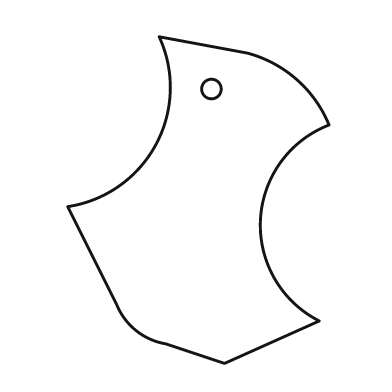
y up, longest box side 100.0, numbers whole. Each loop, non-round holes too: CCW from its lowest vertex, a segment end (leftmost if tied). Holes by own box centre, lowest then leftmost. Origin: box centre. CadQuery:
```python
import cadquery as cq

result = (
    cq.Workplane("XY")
    .moveTo(8.0, -50.0)
    .lineTo(37.0, -37.0)
    .threePointArc((19.0, -6.0), (40.0, 23.0))
    .threePointArc((30.0, 37.0), (15.0, 45.0))
    .lineTo(-12.0, 50.0)
    .threePointArc((-13.0, 17.0), (-40.0, -2.0))
    .lineTo(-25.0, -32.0)
    .threePointArc((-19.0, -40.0), (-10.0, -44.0))
    .close()
    .moveTo(4.0, 34.0)
    .circle(3.0)
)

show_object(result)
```